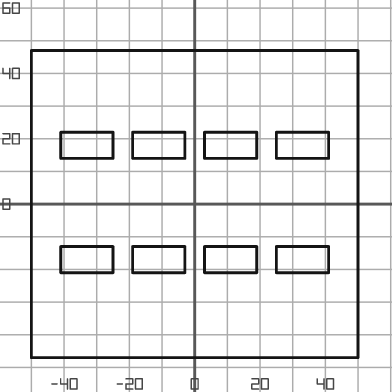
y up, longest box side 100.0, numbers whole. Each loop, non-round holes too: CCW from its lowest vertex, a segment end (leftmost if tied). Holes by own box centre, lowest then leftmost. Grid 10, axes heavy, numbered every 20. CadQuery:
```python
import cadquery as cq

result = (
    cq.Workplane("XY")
    .moveTo(-50.0, -47.0)
    .lineTo(50.0, -47.0)
    .lineTo(50.0, 47.0)
    .lineTo(-50.0, 47.0)
    .close()
    .moveTo(-41.0, -21.0)
    .lineTo(-25.0, -21.0)
    .lineTo(-25.0, -13.0)
    .lineTo(-41.0, -13.0)
    .close()
    .moveTo(-19.0, -21.0)
    .lineTo(-3.0, -21.0)
    .lineTo(-3.0, -13.0)
    .lineTo(-19.0, -13.0)
    .close()
    .moveTo(3.0, -21.0)
    .lineTo(19.0, -21.0)
    .lineTo(19.0, -13.0)
    .lineTo(3.0, -13.0)
    .close()
    .moveTo(25.0, -21.0)
    .lineTo(41.0, -21.0)
    .lineTo(41.0, -13.0)
    .lineTo(25.0, -13.0)
    .close()
    .moveTo(-41.0, 14.0)
    .lineTo(-25.0, 14.0)
    .lineTo(-25.0, 22.0)
    .lineTo(-41.0, 22.0)
    .close()
    .moveTo(-19.0, 14.0)
    .lineTo(-3.0, 14.0)
    .lineTo(-3.0, 22.0)
    .lineTo(-19.0, 22.0)
    .close()
    .moveTo(3.0, 14.0)
    .lineTo(19.0, 14.0)
    .lineTo(19.0, 22.0)
    .lineTo(3.0, 22.0)
    .close()
    .moveTo(25.0, 14.0)
    .lineTo(41.0, 14.0)
    .lineTo(41.0, 22.0)
    .lineTo(25.0, 22.0)
    .close()
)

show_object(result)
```